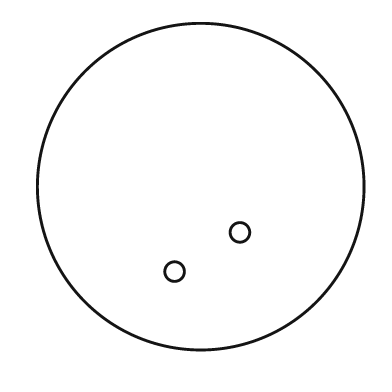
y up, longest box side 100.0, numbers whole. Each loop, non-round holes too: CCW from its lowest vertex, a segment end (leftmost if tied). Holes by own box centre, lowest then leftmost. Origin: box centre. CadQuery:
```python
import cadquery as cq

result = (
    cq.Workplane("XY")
    .moveTo(0.0, 0.0)
    .circle(50.0)
    .moveTo(-8.0, -26.0)
    .circle(3.0)
    .moveTo(12.0, -14.0)
    .circle(3.0)
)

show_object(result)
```